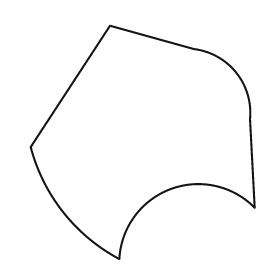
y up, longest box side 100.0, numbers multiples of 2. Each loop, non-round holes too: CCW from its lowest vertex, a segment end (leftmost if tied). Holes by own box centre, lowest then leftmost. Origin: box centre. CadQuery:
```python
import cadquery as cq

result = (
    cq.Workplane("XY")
    .moveTo(-10.0, -50.0)
    .threePointArc((12.0, -20.0), (48.0, -28.0))
    .lineTo(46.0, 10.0)
    .threePointArc((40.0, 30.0), (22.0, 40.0))
    .lineTo(-14.0, 50.0)
    .lineTo(-48.0, -2.0)
    .threePointArc((-34.0, -30.0), (-10.0, -50.0))
    .close()
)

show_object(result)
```